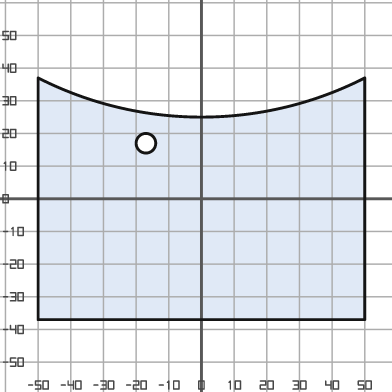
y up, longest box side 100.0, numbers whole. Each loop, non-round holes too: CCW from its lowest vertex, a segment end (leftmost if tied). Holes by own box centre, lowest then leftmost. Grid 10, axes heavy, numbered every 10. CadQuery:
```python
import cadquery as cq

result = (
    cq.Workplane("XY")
    .moveTo(-50.0, -37.0)
    .lineTo(50.0, -37.0)
    .lineTo(50.0, 37.0)
    .threePointArc((0.0, 25.0), (-50.0, 37.0))
    .close()
    .moveTo(-17.0, 17.0)
    .circle(3.0)
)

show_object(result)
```